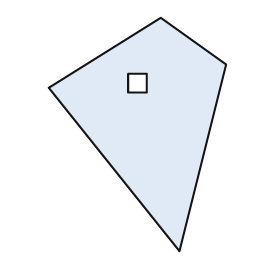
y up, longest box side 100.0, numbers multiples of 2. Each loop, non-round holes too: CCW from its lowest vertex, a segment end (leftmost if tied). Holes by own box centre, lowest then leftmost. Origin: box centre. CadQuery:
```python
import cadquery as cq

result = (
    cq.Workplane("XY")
    .moveTo(18.0, -50.0)
    .lineTo(38.0, 30.0)
    .lineTo(10.0, 50.0)
    .lineTo(-38.0, 20.0)
    .close()
    .moveTo(-4.0, 18.0)
    .lineTo(4.0, 18.0)
    .lineTo(4.0, 26.0)
    .lineTo(-4.0, 26.0)
    .close()
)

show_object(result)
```